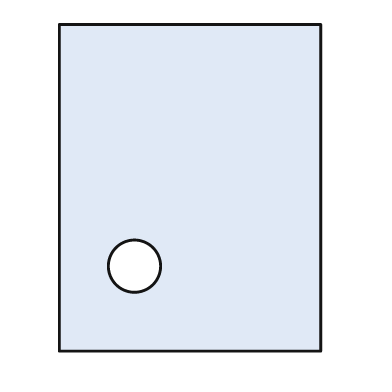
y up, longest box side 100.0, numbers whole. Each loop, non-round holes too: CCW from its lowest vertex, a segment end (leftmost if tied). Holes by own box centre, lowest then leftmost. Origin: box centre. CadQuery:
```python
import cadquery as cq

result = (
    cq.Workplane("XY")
    .moveTo(-40.0, -50.0)
    .lineTo(40.0, -50.0)
    .lineTo(40.0, 50.0)
    .lineTo(-40.0, 50.0)
    .close()
    .moveTo(-17.0, -24.0)
    .circle(8.0)
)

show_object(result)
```